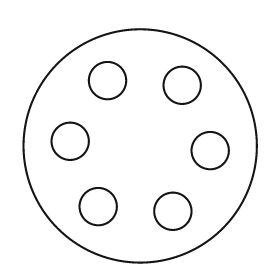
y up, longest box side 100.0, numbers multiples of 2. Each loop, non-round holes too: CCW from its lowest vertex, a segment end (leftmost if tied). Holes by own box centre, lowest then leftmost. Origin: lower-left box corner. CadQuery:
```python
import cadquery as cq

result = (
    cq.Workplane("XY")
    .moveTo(50.0, 50.0)
    .circle(50.0)
    .moveTo(64.0, 22.0)
    .circle(8.0)
    .moveTo(32.0, 24.0)
    .circle(8.0)
    .moveTo(80.0, 48.0)
    .circle(8.0)
    .moveTo(20.0, 52.0)
    .circle(8.0)
    .moveTo(68.0, 76.0)
    .circle(8.0)
    .moveTo(36.0, 78.0)
    .circle(8.0)
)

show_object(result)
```